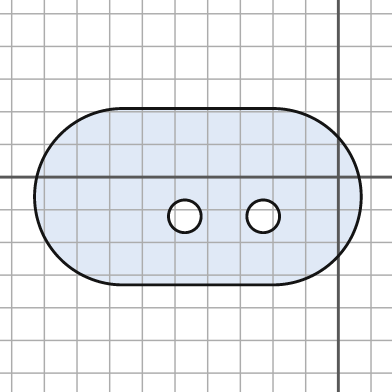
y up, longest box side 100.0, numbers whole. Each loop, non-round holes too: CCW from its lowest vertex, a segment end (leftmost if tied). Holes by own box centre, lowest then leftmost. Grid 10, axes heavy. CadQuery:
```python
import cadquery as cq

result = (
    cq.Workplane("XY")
    .moveTo(-66.0, -33.0)
    .lineTo(-20.0, -33.0)
    .threePointArc((7.0, -6.0), (-20.0, 21.0))
    .lineTo(-66.0, 21.0)
    .threePointArc((-93.0, -6.0), (-66.0, -33.0))
    .close()
    .moveTo(-47.0, -12.0)
    .circle(5.0)
    .moveTo(-23.0, -12.0)
    .circle(5.0)
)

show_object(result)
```